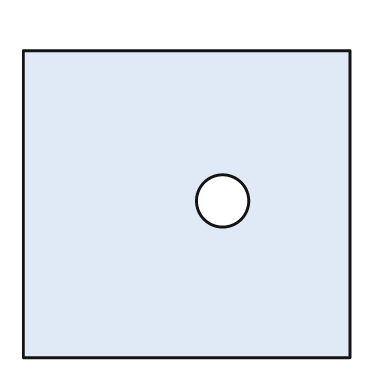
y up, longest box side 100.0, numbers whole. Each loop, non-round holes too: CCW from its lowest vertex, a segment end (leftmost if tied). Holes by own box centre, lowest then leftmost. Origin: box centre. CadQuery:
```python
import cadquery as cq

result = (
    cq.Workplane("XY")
    .moveTo(-50.0, -47.0)
    .lineTo(50.0, -47.0)
    .lineTo(50.0, 47.0)
    .lineTo(-50.0, 47.0)
    .close()
    .moveTo(11.0, 1.0)
    .circle(8.0)
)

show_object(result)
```